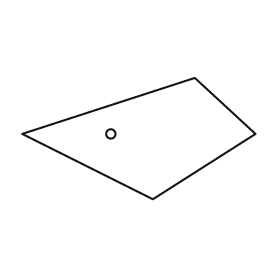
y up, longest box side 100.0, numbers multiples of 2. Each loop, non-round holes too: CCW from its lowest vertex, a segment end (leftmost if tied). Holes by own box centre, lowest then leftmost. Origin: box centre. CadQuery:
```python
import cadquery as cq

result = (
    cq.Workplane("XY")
    .moveTo(6.0, -26.0)
    .lineTo(50.0, 2.0)
    .lineTo(24.0, 26.0)
    .lineTo(-50.0, 2.0)
    .close()
    .moveTo(-12.0, 2.0)
    .circle(2.0)
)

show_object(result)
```